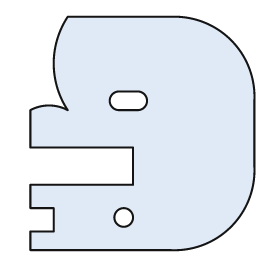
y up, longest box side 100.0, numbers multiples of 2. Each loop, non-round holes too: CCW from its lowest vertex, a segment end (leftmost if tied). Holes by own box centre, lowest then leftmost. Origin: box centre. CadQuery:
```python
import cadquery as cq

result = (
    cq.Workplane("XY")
    .moveTo(-48.0, -50.0)
    .lineTo(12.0, -50.0)
    .threePointArc((38.0, -40.0), (48.0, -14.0))
    .lineTo(48.0, 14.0)
    .threePointArc((38.0, 40.0), (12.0, 50.0))
    .lineTo(-32.0, 50.0)
    .threePointArc((-38.0, 30.0), (-32.0, 10.0))
    .threePointArc((-40.0, 12.0), (-48.0, 10.0))
    .lineTo(-48.0, -6.0)
    .lineTo(-4.0, -6.0)
    .lineTo(-4.0, -22.0)
    .lineTo(-48.0, -22.0)
    .lineTo(-48.0, -32.0)
    .lineTo(-38.0, -32.0)
    .lineTo(-38.0, -42.0)
    .lineTo(-48.0, -42.0)
    .close()
    .moveTo(-8.0, -36.0)
    .circle(4.0)
    .moveTo(-10.0, 10.0)
    .lineTo(-2.0, 10.0)
    .threePointArc((2.0, 14.0), (-2.0, 18.0))
    .lineTo(-10.0, 18.0)
    .threePointArc((-14.0, 14.0), (-10.0, 10.0))
    .close()
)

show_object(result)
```